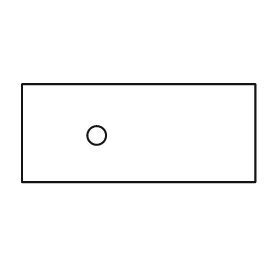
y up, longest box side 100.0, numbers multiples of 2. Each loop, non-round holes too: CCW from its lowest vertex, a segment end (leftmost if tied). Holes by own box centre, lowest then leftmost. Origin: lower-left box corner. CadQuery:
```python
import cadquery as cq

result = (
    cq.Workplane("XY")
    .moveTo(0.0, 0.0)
    .lineTo(100.0, 0.0)
    .lineTo(100.0, 42.0)
    .lineTo(0.0, 42.0)
    .close()
    .moveTo(32.0, 20.0)
    .circle(4.0)
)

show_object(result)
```